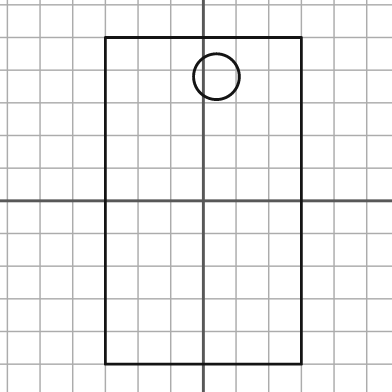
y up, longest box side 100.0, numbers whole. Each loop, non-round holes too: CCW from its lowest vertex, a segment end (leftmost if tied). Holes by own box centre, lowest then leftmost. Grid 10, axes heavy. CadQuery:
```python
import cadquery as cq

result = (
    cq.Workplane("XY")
    .moveTo(-30.0, -50.0)
    .lineTo(30.0, -50.0)
    .lineTo(30.0, 50.0)
    .lineTo(-30.0, 50.0)
    .close()
    .moveTo(4.0, 38.0)
    .circle(7.0)
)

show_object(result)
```